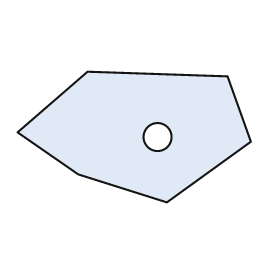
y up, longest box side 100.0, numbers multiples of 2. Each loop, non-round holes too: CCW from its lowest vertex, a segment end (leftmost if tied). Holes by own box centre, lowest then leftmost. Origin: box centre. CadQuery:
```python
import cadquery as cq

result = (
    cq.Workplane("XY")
    .moveTo(14.0, -28.0)
    .lineTo(50.0, -2.0)
    .lineTo(40.0, 26.0)
    .lineTo(-20.0, 28.0)
    .lineTo(-50.0, 2.0)
    .lineTo(-24.0, -16.0)
    .close()
    .moveTo(10.0, 0.0)
    .circle(6.0)
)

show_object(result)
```